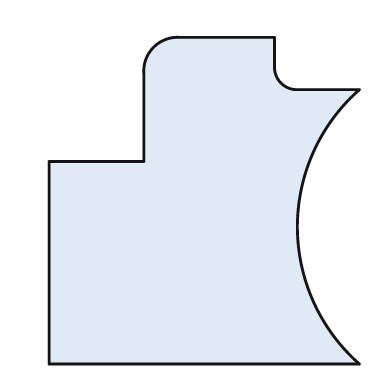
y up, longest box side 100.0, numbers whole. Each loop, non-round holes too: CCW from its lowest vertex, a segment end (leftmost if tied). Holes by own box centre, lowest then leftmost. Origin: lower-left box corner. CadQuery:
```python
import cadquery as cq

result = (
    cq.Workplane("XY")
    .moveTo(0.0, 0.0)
    .lineTo(95.0, 0.0)
    .threePointArc((76.0, 42.0), (95.0, 84.0))
    .lineTo(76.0, 84.0)
    .threePointArc((71.0, 86.0), (69.0, 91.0))
    .lineTo(69.0, 100.0)
    .lineTo(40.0, 100.0)
    .threePointArc((32.0, 97.0), (29.0, 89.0))
    .lineTo(29.0, 62.0)
    .lineTo(0.0, 62.0)
    .close()
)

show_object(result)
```